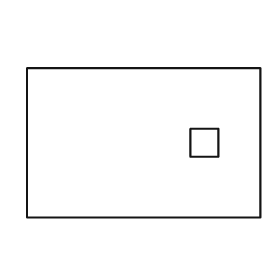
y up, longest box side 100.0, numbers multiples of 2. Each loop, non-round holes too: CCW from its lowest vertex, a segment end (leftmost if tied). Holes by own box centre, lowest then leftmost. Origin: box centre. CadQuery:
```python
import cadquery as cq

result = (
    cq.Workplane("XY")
    .moveTo(-50.0, -32.0)
    .lineTo(50.0, -32.0)
    .lineTo(50.0, 32.0)
    .lineTo(-50.0, 32.0)
    .close()
    .moveTo(20.0, -6.0)
    .lineTo(32.0, -6.0)
    .lineTo(32.0, 6.0)
    .lineTo(20.0, 6.0)
    .close()
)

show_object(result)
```